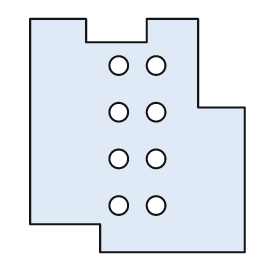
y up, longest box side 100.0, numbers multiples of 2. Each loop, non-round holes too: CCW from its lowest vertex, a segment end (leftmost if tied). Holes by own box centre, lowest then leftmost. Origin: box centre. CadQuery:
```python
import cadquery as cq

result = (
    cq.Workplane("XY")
    .moveTo(-16.0, -50.0)
    .lineTo(46.0, -50.0)
    .lineTo(46.0, 12.0)
    .lineTo(26.0, 12.0)
    .lineTo(26.0, 50.0)
    .lineTo(4.0, 50.0)
    .lineTo(4.0, 40.0)
    .lineTo(-22.0, 40.0)
    .lineTo(-22.0, 50.0)
    .lineTo(-46.0, 50.0)
    .lineTo(-46.0, -38.0)
    .lineTo(-16.0, -38.0)
    .close()
    .moveTo(-8.0, -30.0)
    .circle(4.0)
    .moveTo(8.0, -30.0)
    .circle(4.0)
    .moveTo(-8.0, -10.0)
    .circle(4.0)
    .moveTo(8.0, -10.0)
    .circle(4.0)
    .moveTo(-8.0, 10.0)
    .circle(4.0)
    .moveTo(8.0, 10.0)
    .circle(4.0)
    .moveTo(-8.0, 30.0)
    .circle(4.0)
    .moveTo(8.0, 30.0)
    .circle(4.0)
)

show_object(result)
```